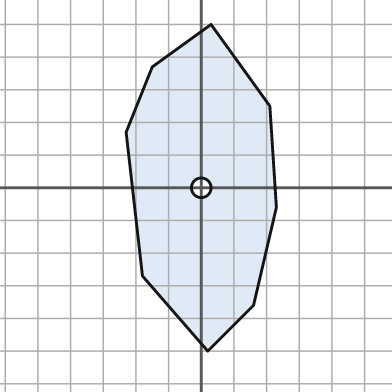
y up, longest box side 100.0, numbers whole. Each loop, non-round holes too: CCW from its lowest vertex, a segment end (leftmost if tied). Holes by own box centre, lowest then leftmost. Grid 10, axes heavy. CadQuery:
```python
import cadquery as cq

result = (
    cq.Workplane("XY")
    .moveTo(2.0, -50.0)
    .lineTo(16.0, -36.0)
    .lineTo(23.0, -6.0)
    .lineTo(21.0, 25.0)
    .lineTo(3.0, 50.0)
    .lineTo(-15.0, 37.0)
    .lineTo(-23.0, 17.0)
    .lineTo(-18.0, -27.0)
    .close()
    .moveTo(0.0, 0.0)
    .circle(3.0)
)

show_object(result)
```